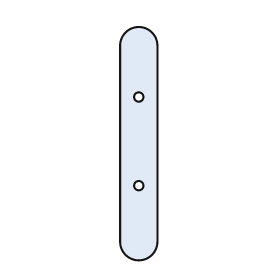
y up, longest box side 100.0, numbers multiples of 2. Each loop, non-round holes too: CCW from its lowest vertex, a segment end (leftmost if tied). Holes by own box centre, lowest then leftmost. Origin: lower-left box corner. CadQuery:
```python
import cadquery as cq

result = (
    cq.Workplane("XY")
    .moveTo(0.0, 8.0)
    .threePointArc((8.0, 0.0), (16.0, 8.0))
    .lineTo(16.0, 92.0)
    .threePointArc((8.0, 100.0), (0.0, 92.0))
    .close()
    .moveTo(8.0, 32.0)
    .circle(2.0)
    .moveTo(8.0, 70.0)
    .circle(2.0)
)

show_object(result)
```